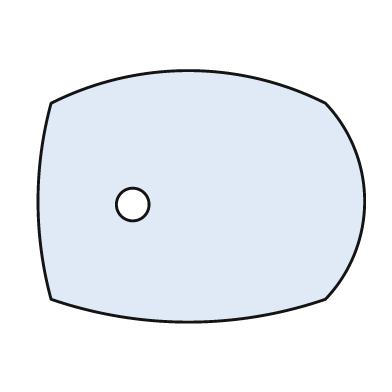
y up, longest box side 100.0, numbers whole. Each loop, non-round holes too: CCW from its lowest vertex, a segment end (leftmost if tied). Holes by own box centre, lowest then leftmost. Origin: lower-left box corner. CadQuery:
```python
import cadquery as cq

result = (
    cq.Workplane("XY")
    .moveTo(4.0, 7.0)
    .threePointArc((46.0, 0.0), (88.0, 7.0))
    .threePointArc((100.0, 37.0), (88.0, 67.0))
    .threePointArc((46.0, 77.0), (4.0, 67.0))
    .threePointArc((0.0, 37.0), (4.0, 7.0))
    .close()
    .moveTo(29.0, 36.0)
    .circle(5.0)
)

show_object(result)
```